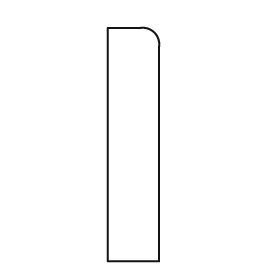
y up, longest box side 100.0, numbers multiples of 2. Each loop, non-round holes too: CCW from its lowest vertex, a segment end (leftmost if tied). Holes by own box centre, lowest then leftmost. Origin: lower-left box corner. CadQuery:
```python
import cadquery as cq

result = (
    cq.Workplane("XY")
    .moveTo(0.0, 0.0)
    .lineTo(22.0, 0.0)
    .lineTo(22.0, 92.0)
    .threePointArc((20.0, 98.0), (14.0, 100.0))
    .lineTo(0.0, 100.0)
    .close()
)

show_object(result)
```